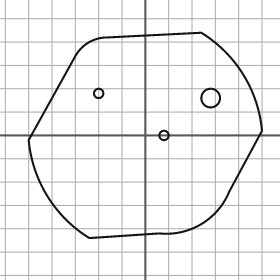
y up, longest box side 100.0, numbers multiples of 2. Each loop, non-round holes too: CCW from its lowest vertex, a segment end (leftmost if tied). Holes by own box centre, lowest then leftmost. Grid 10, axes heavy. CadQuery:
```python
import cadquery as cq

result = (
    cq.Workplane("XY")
    .moveTo(-24.0, -44.0)
    .lineTo(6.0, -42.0)
    .threePointArc((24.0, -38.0), (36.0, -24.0))
    .lineTo(50.0, 2.0)
    .threePointArc((42.0, 26.0), (24.0, 44.0))
    .lineTo(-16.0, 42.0)
    .threePointArc((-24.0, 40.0), (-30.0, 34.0))
    .lineTo(-50.0, -2.0)
    .threePointArc((-42.0, -26.0), (-24.0, -44.0))
    .close()
    .moveTo(8.0, 0.0)
    .circle(2.0)
    .moveTo(28.0, 16.0)
    .circle(4.0)
    .moveTo(-20.0, 18.0)
    .circle(2.0)
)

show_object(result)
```